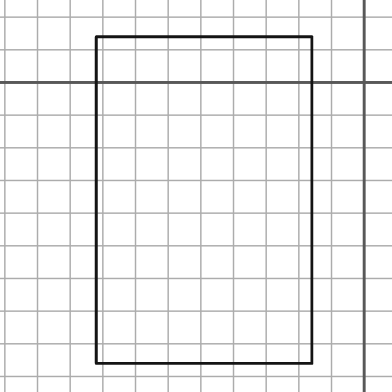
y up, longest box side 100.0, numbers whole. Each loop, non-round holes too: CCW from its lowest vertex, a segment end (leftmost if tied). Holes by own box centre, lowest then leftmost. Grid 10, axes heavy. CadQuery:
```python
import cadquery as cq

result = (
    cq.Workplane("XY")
    .moveTo(-82.0, -86.0)
    .lineTo(-16.0, -86.0)
    .lineTo(-16.0, 14.0)
    .lineTo(-82.0, 14.0)
    .close()
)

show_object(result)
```